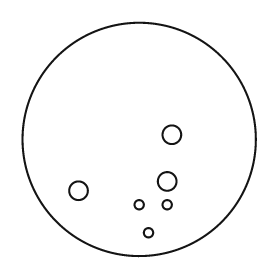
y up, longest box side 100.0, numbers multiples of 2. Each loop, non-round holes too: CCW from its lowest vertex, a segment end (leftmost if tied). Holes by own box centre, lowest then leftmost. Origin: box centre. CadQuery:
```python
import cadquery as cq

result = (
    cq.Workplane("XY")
    .moveTo(0.0, 0.0)
    .circle(50.0)
    .moveTo(4.0, -40.0)
    .circle(2.0)
    .moveTo(0.0, -28.0)
    .circle(2.0)
    .moveTo(12.0, -28.0)
    .circle(2.0)
    .moveTo(-26.0, -22.0)
    .circle(4.0)
    .moveTo(12.0, -18.0)
    .circle(4.0)
    .moveTo(14.0, 2.0)
    .circle(4.0)
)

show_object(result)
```